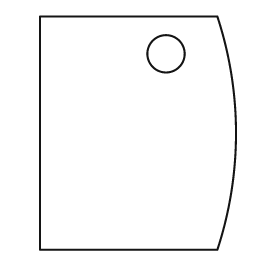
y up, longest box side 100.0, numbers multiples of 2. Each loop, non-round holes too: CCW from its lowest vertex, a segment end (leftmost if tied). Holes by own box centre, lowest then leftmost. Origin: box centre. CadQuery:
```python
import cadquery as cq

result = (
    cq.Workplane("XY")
    .moveTo(-42.0, -50.0)
    .lineTo(34.0, -50.0)
    .threePointArc((42.0, 0.0), (34.0, 50.0))
    .lineTo(-42.0, 50.0)
    .close()
    .moveTo(12.0, 34.0)
    .circle(8.0)
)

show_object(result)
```